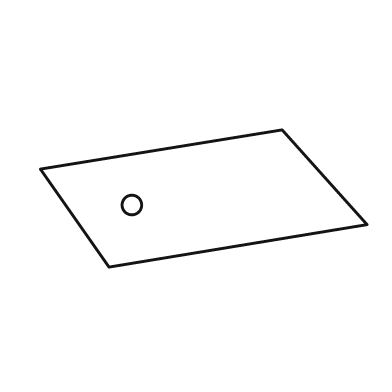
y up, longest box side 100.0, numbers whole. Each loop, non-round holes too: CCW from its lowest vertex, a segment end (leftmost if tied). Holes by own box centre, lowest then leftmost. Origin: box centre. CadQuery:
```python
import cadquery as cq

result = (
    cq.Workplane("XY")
    .moveTo(-29.0, -21.0)
    .lineTo(50.0, -8.0)
    .lineTo(24.0, 21.0)
    .lineTo(-50.0, 9.0)
    .close()
    .moveTo(-22.0, -2.0)
    .circle(3.0)
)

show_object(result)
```